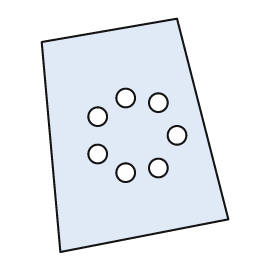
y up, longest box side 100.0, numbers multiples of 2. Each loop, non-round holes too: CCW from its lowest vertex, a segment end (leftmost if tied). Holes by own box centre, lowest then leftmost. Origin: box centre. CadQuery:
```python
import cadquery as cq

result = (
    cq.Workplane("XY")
    .moveTo(-32.0, -50.0)
    .lineTo(40.0, -36.0)
    .lineTo(18.0, 50.0)
    .lineTo(-40.0, 40.0)
    .close()
    .moveTo(-4.0, -16.0)
    .circle(4.0)
    .moveTo(10.0, -14.0)
    .circle(4.0)
    .moveTo(-16.0, -8.0)
    .circle(4.0)
    .moveTo(18.0, 0.0)
    .circle(4.0)
    .moveTo(-16.0, 8.0)
    .circle(4.0)
    .moveTo(10.0, 14.0)
    .circle(4.0)
    .moveTo(-4.0, 16.0)
    .circle(4.0)
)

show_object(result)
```